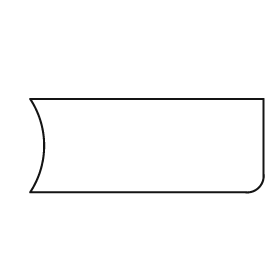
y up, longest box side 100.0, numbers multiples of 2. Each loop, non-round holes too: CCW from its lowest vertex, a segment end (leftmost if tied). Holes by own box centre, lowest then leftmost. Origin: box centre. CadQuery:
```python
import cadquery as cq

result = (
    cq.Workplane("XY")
    .moveTo(-50.0, -20.0)
    .lineTo(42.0, -20.0)
    .threePointArc((48.0, -18.0), (50.0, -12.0))
    .lineTo(50.0, 20.0)
    .lineTo(-50.0, 20.0)
    .threePointArc((-44.0, 0.0), (-50.0, -20.0))
    .close()
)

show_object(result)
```